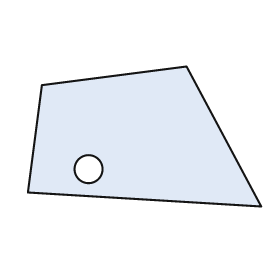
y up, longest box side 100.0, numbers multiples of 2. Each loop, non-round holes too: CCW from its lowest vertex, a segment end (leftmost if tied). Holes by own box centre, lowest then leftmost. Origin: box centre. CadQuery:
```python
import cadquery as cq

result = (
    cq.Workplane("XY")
    .moveTo(50.0, -30.0)
    .lineTo(18.0, 30.0)
    .lineTo(-44.0, 22.0)
    .lineTo(-50.0, -24.0)
    .close()
    .moveTo(-24.0, -14.0)
    .circle(6.0)
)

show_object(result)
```